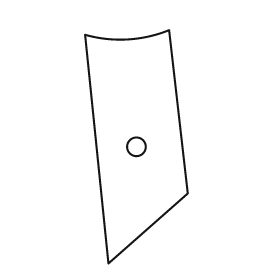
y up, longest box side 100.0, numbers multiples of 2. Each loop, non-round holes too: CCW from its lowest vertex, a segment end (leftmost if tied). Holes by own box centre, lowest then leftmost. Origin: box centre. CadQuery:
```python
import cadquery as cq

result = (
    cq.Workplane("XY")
    .moveTo(-12.0, -50.0)
    .lineTo(22.0, -20.0)
    .lineTo(14.0, 50.0)
    .threePointArc((-4.0, 46.0), (-22.0, 48.0))
    .close()
    .moveTo(0.0, 0.0)
    .circle(4.0)
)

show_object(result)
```